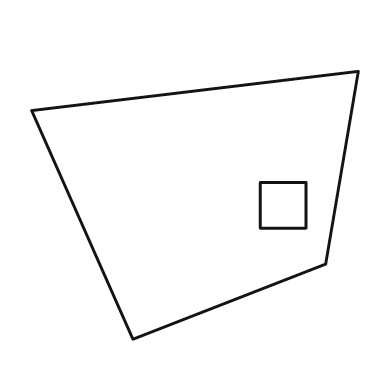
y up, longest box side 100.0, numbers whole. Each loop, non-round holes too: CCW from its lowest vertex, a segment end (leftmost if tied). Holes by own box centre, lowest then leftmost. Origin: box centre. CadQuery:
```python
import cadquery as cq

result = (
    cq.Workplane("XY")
    .moveTo(-19.0, -41.0)
    .lineTo(40.0, -18.0)
    .lineTo(50.0, 41.0)
    .lineTo(-50.0, 29.0)
    .close()
    .moveTo(20.0, -7.0)
    .lineTo(34.0, -7.0)
    .lineTo(34.0, 7.0)
    .lineTo(20.0, 7.0)
    .close()
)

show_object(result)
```